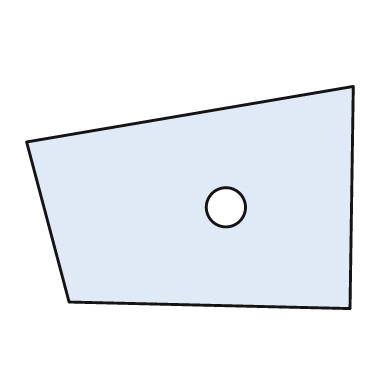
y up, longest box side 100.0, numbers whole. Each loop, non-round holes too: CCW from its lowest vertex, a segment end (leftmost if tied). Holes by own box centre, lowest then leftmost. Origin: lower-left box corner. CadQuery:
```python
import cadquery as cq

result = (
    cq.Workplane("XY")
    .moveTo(99.0, 0.0)
    .lineTo(100.0, 68.0)
    .lineTo(0.0, 51.0)
    .lineTo(13.0, 2.0)
    .close()
    .moveTo(61.0, 31.0)
    .circle(6.0)
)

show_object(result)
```